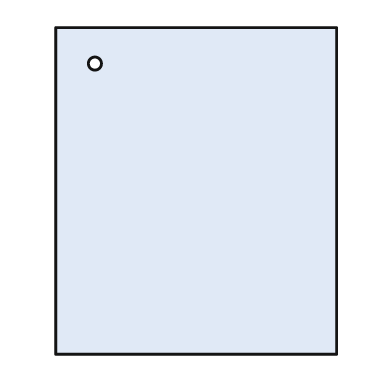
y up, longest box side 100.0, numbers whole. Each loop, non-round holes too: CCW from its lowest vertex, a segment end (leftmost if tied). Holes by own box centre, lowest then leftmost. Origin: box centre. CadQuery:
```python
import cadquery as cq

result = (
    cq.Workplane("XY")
    .moveTo(-43.0, -50.0)
    .lineTo(43.0, -50.0)
    .lineTo(43.0, 50.0)
    .lineTo(-43.0, 50.0)
    .close()
    .moveTo(-31.0, 39.0)
    .circle(2.0)
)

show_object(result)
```